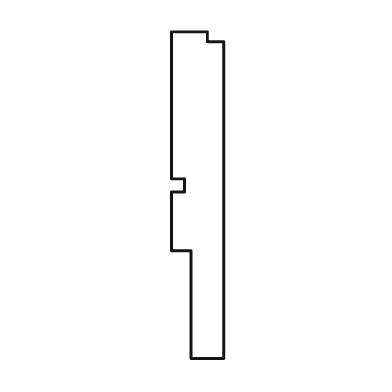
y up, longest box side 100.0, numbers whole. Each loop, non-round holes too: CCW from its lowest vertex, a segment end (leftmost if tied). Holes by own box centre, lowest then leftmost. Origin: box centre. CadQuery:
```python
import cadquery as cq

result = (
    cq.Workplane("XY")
    .moveTo(-2.0, -50.0)
    .lineTo(8.0, -50.0)
    .lineTo(8.0, 47.0)
    .lineTo(3.0, 47.0)
    .lineTo(3.0, 50.0)
    .lineTo(-8.0, 50.0)
    .lineTo(-8.0, 5.0)
    .lineTo(-4.0, 5.0)
    .lineTo(-4.0, 1.0)
    .lineTo(-8.0, 1.0)
    .lineTo(-8.0, -17.0)
    .lineTo(-2.0, -17.0)
    .close()
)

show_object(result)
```